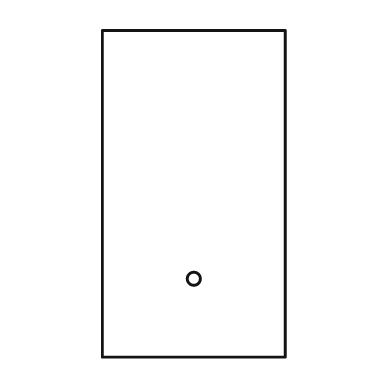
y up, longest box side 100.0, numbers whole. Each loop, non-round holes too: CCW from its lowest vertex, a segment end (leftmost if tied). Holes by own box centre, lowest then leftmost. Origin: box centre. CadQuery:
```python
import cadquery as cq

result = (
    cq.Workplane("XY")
    .moveTo(-28.0, -50.0)
    .lineTo(28.0, -50.0)
    .lineTo(28.0, 50.0)
    .lineTo(-28.0, 50.0)
    .close()
    .moveTo(0.0, -26.0)
    .circle(2.0)
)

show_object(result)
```